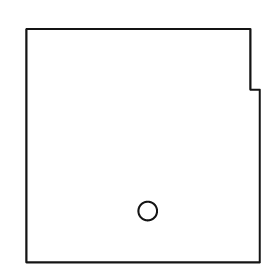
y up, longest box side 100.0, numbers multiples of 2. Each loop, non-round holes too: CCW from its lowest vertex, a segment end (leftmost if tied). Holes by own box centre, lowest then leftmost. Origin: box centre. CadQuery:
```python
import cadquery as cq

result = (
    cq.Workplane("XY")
    .moveTo(-50.0, -50.0)
    .lineTo(50.0, -50.0)
    .lineTo(50.0, 24.0)
    .lineTo(46.0, 24.0)
    .lineTo(46.0, 50.0)
    .lineTo(-50.0, 50.0)
    .close()
    .moveTo(2.0, -28.0)
    .circle(4.0)
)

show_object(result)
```